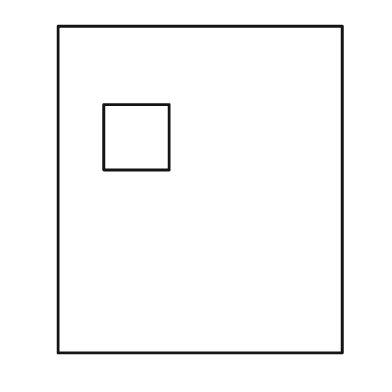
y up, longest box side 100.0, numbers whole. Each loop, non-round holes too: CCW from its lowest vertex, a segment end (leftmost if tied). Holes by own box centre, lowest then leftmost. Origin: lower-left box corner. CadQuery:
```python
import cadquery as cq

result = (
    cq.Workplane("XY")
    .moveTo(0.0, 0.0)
    .lineTo(87.0, 0.0)
    .lineTo(87.0, 100.0)
    .lineTo(0.0, 100.0)
    .close()
    .moveTo(14.0, 56.0)
    .lineTo(34.0, 56.0)
    .lineTo(34.0, 76.0)
    .lineTo(14.0, 76.0)
    .close()
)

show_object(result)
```